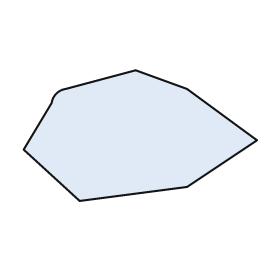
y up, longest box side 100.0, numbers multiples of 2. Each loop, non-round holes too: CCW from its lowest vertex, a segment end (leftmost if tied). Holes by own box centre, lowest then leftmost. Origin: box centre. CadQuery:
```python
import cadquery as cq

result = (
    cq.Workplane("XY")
    .moveTo(-26.0, -28.0)
    .lineTo(20.0, -22.0)
    .lineTo(50.0, -2.0)
    .lineTo(20.0, 20.0)
    .lineTo(-2.0, 28.0)
    .lineTo(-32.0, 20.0)
    .threePointArc((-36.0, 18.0), (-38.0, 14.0))
    .lineTo(-50.0, -6.0)
    .close()
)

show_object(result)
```